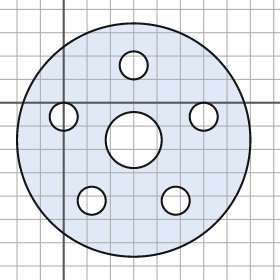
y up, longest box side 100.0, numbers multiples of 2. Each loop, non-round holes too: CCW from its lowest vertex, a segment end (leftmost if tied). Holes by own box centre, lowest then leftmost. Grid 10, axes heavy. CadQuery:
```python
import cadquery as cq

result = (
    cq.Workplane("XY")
    .moveTo(30.0, -16.0)
    .circle(50.0)
    .moveTo(12.0, -42.0)
    .circle(6.0)
    .moveTo(48.0, -42.0)
    .circle(6.0)
    .moveTo(30.0, -16.0)
    .circle(12.0)
    .moveTo(0.0, -6.0)
    .circle(6.0)
    .moveTo(60.0, -6.0)
    .circle(6.0)
    .moveTo(30.0, 16.0)
    .circle(6.0)
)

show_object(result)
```